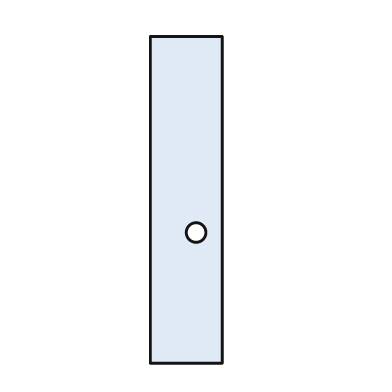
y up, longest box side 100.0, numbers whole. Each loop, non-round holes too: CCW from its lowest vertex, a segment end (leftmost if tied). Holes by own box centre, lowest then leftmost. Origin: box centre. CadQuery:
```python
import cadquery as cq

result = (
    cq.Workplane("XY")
    .moveTo(-11.0, -50.0)
    .lineTo(11.0, -50.0)
    .lineTo(11.0, 50.0)
    .lineTo(-11.0, 50.0)
    .close()
    .moveTo(3.0, -10.0)
    .circle(3.0)
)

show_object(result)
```